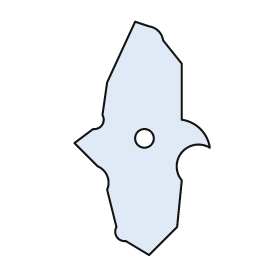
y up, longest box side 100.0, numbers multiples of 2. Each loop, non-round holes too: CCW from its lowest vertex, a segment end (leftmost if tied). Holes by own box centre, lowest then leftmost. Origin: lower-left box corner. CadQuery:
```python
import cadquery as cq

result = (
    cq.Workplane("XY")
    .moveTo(32.0, 0.0)
    .lineTo(44.0, 12.0)
    .lineTo(46.0, 32.0)
    .threePointArc((46.0, 44.0), (58.0, 46.0))
    .threePointArc((54.0, 54.0), (46.0, 58.0))
    .lineTo(46.0, 82.0)
    .lineTo(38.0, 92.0)
    .threePointArc((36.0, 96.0), (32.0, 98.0))
    .lineTo(26.0, 100.0)
    .lineTo(14.0, 74.0)
    .lineTo(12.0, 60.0)
    .threePointArc((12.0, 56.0), (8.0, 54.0))
    .lineTo(0.0, 48.0)
    .lineTo(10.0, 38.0)
    .threePointArc((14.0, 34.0), (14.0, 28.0))
    .lineTo(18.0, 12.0)
    .threePointArc((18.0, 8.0), (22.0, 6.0))
    .close()
    .moveTo(30.0, 50.0)
    .circle(4.0)
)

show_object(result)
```